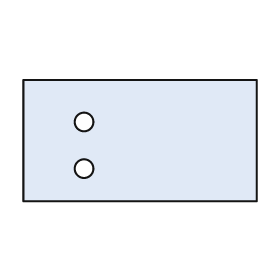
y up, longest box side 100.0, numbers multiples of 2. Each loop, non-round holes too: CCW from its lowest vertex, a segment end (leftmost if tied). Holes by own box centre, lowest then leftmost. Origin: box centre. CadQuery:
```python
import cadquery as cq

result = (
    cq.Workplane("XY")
    .moveTo(-50.0, -26.0)
    .lineTo(50.0, -26.0)
    .lineTo(50.0, 26.0)
    .lineTo(-50.0, 26.0)
    .close()
    .moveTo(-24.0, -12.0)
    .circle(4.0)
    .moveTo(-24.0, 8.0)
    .circle(4.0)
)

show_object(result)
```